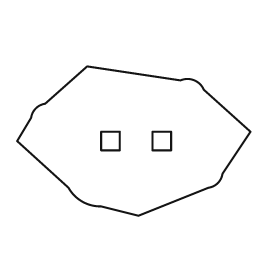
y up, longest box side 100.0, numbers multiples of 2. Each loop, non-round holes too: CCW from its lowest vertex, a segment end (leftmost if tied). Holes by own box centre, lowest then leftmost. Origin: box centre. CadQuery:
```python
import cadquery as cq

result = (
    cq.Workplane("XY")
    .moveTo(2.0, -32.0)
    .lineTo(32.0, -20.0)
    .threePointArc((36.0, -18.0), (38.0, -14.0))
    .lineTo(50.0, 4.0)
    .lineTo(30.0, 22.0)
    .threePointArc((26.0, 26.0), (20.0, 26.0))
    .lineTo(-20.0, 32.0)
    .lineTo(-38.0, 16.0)
    .threePointArc((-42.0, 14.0), (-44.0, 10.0))
    .lineTo(-50.0, 0.0)
    .lineTo(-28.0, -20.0)
    .threePointArc((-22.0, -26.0), (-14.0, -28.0))
    .close()
    .moveTo(-14.0, -4.0)
    .lineTo(-6.0, -4.0)
    .lineTo(-6.0, 4.0)
    .lineTo(-14.0, 4.0)
    .close()
    .moveTo(8.0, -4.0)
    .lineTo(16.0, -4.0)
    .lineTo(16.0, 4.0)
    .lineTo(8.0, 4.0)
    .close()
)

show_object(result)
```